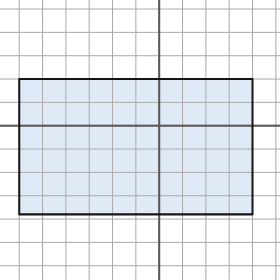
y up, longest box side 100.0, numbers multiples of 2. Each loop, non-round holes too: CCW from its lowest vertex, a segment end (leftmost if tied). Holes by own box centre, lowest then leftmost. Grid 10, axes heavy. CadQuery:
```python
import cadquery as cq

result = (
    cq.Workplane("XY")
    .moveTo(-60.0, -38.0)
    .lineTo(40.0, -38.0)
    .lineTo(40.0, 20.0)
    .lineTo(-60.0, 20.0)
    .close()
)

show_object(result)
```